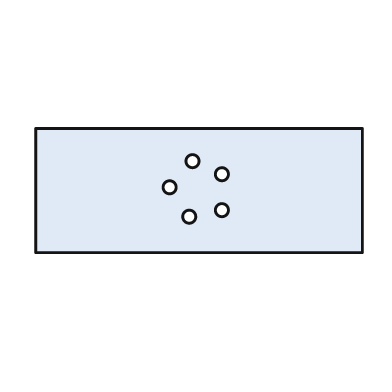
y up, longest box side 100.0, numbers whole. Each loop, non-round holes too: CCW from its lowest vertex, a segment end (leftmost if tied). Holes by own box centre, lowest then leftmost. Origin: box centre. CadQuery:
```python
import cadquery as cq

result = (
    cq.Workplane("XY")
    .moveTo(-50.0, -19.0)
    .lineTo(50.0, -19.0)
    .lineTo(50.0, 19.0)
    .lineTo(-50.0, 19.0)
    .close()
    .moveTo(-3.0, -8.0)
    .circle(2.0)
    .moveTo(7.0, -6.0)
    .circle(2.0)
    .moveTo(-9.0, 1.0)
    .circle(2.0)
    .moveTo(7.0, 5.0)
    .circle(2.0)
    .moveTo(-2.0, 9.0)
    .circle(2.0)
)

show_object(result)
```